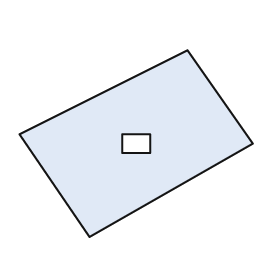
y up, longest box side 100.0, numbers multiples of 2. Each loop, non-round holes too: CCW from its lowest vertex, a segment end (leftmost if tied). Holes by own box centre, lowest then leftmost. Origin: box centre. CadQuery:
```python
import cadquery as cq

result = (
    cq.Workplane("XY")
    .moveTo(-20.0, -40.0)
    .lineTo(50.0, 0.0)
    .lineTo(22.0, 40.0)
    .lineTo(-50.0, 4.0)
    .close()
    .moveTo(-6.0, -4.0)
    .lineTo(6.0, -4.0)
    .lineTo(6.0, 4.0)
    .lineTo(-6.0, 4.0)
    .close()
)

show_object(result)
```